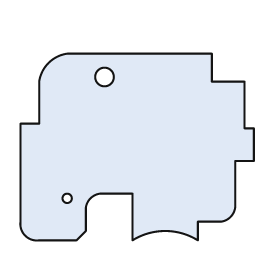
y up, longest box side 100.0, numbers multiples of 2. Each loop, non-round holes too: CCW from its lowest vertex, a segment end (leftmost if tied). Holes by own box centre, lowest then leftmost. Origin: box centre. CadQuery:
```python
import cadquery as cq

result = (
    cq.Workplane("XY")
    .moveTo(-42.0, -40.0)
    .lineTo(-26.0, -40.0)
    .lineTo(-22.0, -36.0)
    .lineTo(-22.0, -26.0)
    .threePointArc((-20.0, -22.0), (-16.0, -20.0))
    .lineTo(-2.0, -20.0)
    .lineTo(-2.0, -40.0)
    .threePointArc((12.0, -36.0), (26.0, -40.0))
    .lineTo(26.0, -32.0)
    .lineTo(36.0, -32.0)
    .threePointArc((40.0, -30.0), (42.0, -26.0))
    .lineTo(42.0, -6.0)
    .lineTo(50.0, -6.0)
    .lineTo(50.0, 8.0)
    .lineTo(46.0, 8.0)
    .lineTo(46.0, 28.0)
    .lineTo(32.0, 28.0)
    .lineTo(32.0, 40.0)
    .lineTo(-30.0, 40.0)
    .threePointArc((-38.0, 36.0), (-42.0, 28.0))
    .lineTo(-42.0, 10.0)
    .lineTo(-50.0, 10.0)
    .lineTo(-50.0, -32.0)
    .threePointArc((-48.0, -38.0), (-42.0, -40.0))
    .close()
    .moveTo(-30.0, -22.0)
    .circle(2.0)
    .moveTo(-14.0, 30.0)
    .circle(4.0)
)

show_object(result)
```